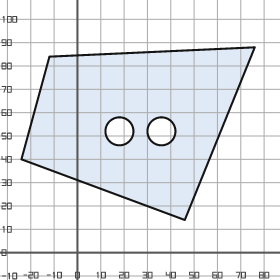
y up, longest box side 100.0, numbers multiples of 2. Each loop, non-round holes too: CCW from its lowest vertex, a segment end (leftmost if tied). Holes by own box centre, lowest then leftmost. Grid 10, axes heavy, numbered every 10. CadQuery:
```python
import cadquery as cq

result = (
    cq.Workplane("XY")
    .moveTo(46.0, 14.0)
    .lineTo(76.0, 88.0)
    .lineTo(-12.0, 84.0)
    .lineTo(-24.0, 40.0)
    .close()
    .moveTo(18.0, 52.0)
    .circle(6.0)
    .moveTo(36.0, 52.0)
    .circle(6.0)
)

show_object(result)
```